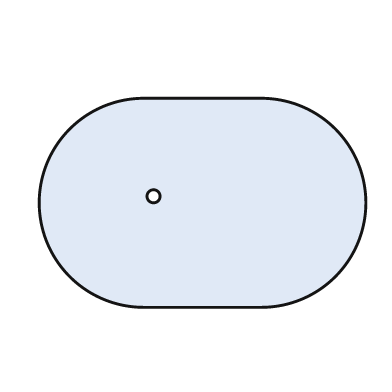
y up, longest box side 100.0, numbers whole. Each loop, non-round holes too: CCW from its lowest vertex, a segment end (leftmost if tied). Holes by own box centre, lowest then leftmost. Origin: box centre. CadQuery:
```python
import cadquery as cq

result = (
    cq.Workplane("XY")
    .moveTo(-18.0, -32.0)
    .lineTo(18.0, -32.0)
    .threePointArc((50.0, 0.0), (18.0, 32.0))
    .lineTo(-18.0, 32.0)
    .threePointArc((-50.0, 0.0), (-18.0, -32.0))
    .close()
    .moveTo(-15.0, 2.0)
    .circle(2.0)
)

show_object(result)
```